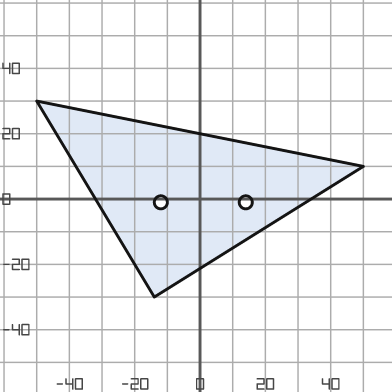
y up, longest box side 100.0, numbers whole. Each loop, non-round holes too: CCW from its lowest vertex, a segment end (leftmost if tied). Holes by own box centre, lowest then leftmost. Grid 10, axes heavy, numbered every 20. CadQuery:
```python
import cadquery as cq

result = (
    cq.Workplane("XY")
    .moveTo(-14.0, -30.0)
    .lineTo(50.0, 10.0)
    .lineTo(-50.0, 30.0)
    .close()
    .moveTo(-12.0, -1.0)
    .circle(2.0)
    .moveTo(14.0, -1.0)
    .circle(2.0)
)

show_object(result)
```